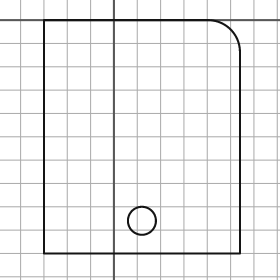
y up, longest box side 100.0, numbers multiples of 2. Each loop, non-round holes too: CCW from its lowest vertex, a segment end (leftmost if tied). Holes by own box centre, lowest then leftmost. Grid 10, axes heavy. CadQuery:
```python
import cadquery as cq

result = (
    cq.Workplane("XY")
    .moveTo(-30.0, -100.0)
    .lineTo(54.0, -100.0)
    .lineTo(54.0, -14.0)
    .threePointArc((50.0, -4.0), (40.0, 0.0))
    .lineTo(-30.0, 0.0)
    .close()
    .moveTo(12.0, -86.0)
    .circle(6.0)
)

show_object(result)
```